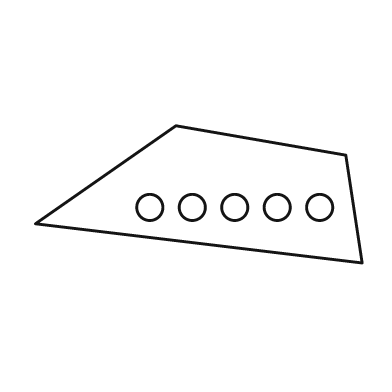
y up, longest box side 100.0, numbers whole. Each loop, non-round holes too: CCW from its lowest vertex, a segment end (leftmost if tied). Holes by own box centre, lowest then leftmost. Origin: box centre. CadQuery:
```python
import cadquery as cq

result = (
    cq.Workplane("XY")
    .moveTo(50.0, -21.0)
    .lineTo(45.0, 12.0)
    .lineTo(-7.0, 21.0)
    .lineTo(-50.0, -9.0)
    .close()
    .moveTo(-15.0, -4.0)
    .circle(4.0)
    .moveTo(-2.0, -4.0)
    .circle(4.0)
    .moveTo(11.0, -4.0)
    .circle(4.0)
    .moveTo(24.0, -4.0)
    .circle(4.0)
    .moveTo(37.0, -4.0)
    .circle(4.0)
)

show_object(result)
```